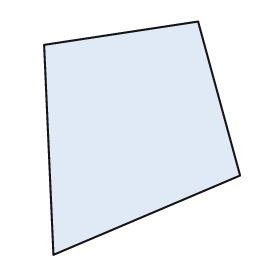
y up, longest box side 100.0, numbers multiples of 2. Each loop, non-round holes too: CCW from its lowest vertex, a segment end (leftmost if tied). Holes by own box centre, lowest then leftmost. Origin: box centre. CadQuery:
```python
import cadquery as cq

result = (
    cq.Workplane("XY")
    .moveTo(-38.0, -50.0)
    .lineTo(42.0, -16.0)
    .lineTo(24.0, 50.0)
    .lineTo(-42.0, 40.0)
    .close()
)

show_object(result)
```